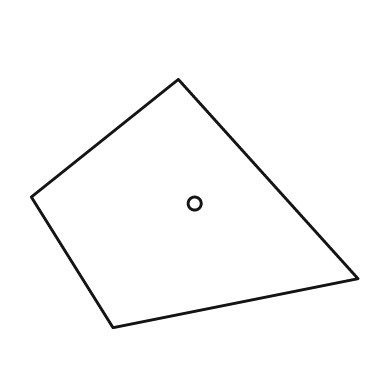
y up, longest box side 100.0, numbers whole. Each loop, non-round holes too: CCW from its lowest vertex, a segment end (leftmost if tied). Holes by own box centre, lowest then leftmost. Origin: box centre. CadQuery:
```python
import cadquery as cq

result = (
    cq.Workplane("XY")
    .moveTo(-25.0, -38.0)
    .lineTo(50.0, -23.0)
    .lineTo(-5.0, 38.0)
    .lineTo(-50.0, 2.0)
    .close()
    .moveTo(0.0, 0.0)
    .circle(2.0)
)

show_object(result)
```